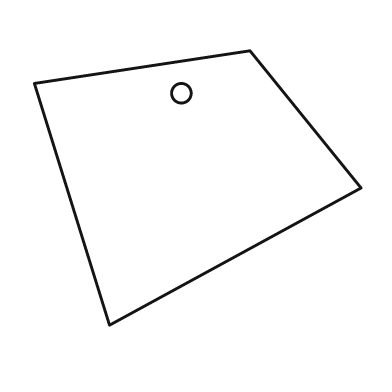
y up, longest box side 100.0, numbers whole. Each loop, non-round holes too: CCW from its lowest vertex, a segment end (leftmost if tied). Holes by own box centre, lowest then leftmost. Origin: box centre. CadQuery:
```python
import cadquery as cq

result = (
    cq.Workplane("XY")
    .moveTo(-27.0, -42.0)
    .lineTo(50.0, 0.0)
    .lineTo(16.0, 42.0)
    .lineTo(-50.0, 32.0)
    .close()
    .moveTo(-5.0, 29.0)
    .circle(3.0)
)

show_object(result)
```